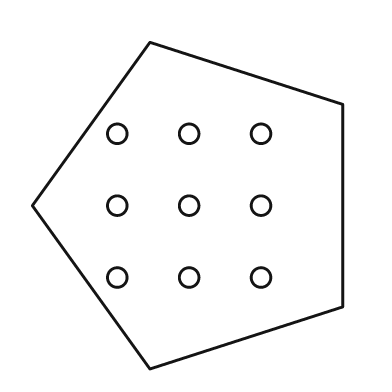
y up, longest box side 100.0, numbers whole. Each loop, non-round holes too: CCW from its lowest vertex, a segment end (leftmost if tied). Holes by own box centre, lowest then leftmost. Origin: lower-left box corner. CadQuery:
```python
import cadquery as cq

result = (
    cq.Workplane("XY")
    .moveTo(36.0, 0.0)
    .lineTo(95.0, 19.0)
    .lineTo(95.0, 81.0)
    .lineTo(36.0, 100.0)
    .lineTo(0.0, 50.0)
    .close()
    .moveTo(26.0, 28.0)
    .circle(3.0)
    .moveTo(48.0, 28.0)
    .circle(3.0)
    .moveTo(70.0, 28.0)
    .circle(3.0)
    .moveTo(26.0, 50.0)
    .circle(3.0)
    .moveTo(48.0, 50.0)
    .circle(3.0)
    .moveTo(70.0, 50.0)
    .circle(3.0)
    .moveTo(26.0, 72.0)
    .circle(3.0)
    .moveTo(48.0, 72.0)
    .circle(3.0)
    .moveTo(70.0, 72.0)
    .circle(3.0)
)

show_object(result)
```